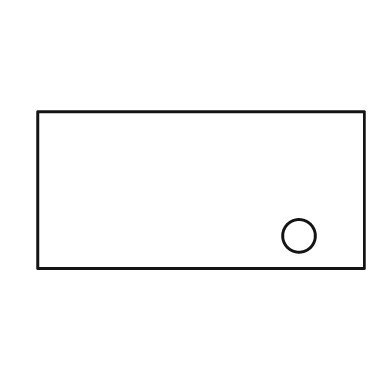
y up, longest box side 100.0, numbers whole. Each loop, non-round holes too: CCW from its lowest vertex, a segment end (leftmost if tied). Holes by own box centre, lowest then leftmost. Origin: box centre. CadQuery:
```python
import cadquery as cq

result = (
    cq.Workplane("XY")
    .moveTo(-50.0, -24.0)
    .lineTo(50.0, -24.0)
    .lineTo(50.0, 24.0)
    .lineTo(-50.0, 24.0)
    .close()
    .moveTo(30.0, -14.0)
    .circle(5.0)
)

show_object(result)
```